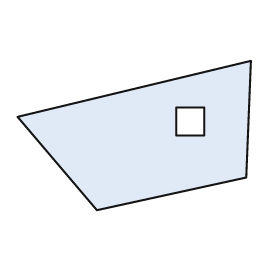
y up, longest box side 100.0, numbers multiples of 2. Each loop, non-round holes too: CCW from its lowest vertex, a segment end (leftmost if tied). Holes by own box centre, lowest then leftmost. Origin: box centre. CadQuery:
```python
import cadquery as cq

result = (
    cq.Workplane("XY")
    .moveTo(-16.0, -32.0)
    .lineTo(48.0, -18.0)
    .lineTo(50.0, 32.0)
    .lineTo(-50.0, 8.0)
    .close()
    .moveTo(18.0, 0.0)
    .lineTo(30.0, 0.0)
    .lineTo(30.0, 12.0)
    .lineTo(18.0, 12.0)
    .close()
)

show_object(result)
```